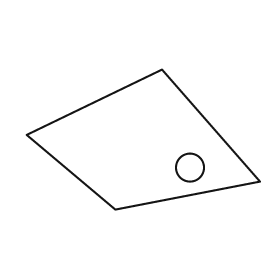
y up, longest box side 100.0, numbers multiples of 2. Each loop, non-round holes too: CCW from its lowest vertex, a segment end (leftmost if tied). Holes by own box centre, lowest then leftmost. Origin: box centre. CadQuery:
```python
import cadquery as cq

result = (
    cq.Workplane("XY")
    .moveTo(-12.0, -30.0)
    .lineTo(50.0, -18.0)
    .lineTo(8.0, 30.0)
    .lineTo(-50.0, 2.0)
    .close()
    .moveTo(20.0, -12.0)
    .circle(6.0)
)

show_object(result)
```